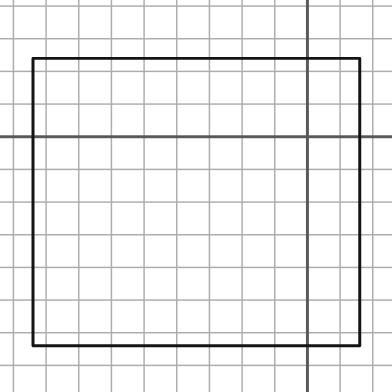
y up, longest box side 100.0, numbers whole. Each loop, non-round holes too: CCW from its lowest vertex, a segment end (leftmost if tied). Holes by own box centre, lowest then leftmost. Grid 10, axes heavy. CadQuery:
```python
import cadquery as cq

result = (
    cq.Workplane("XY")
    .moveTo(-84.0, -64.0)
    .lineTo(16.0, -64.0)
    .lineTo(16.0, 24.0)
    .lineTo(-84.0, 24.0)
    .close()
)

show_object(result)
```